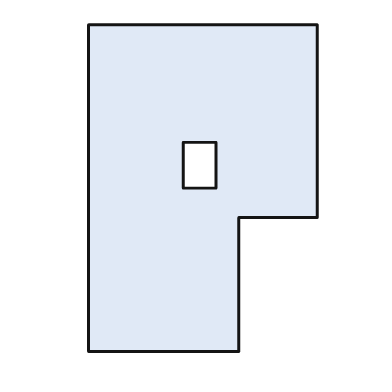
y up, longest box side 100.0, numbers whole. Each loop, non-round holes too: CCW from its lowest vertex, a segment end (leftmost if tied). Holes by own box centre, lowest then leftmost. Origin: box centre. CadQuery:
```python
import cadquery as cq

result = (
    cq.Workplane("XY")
    .moveTo(-35.0, -50.0)
    .lineTo(11.0, -50.0)
    .lineTo(11.0, -9.0)
    .lineTo(35.0, -9.0)
    .lineTo(35.0, 50.0)
    .lineTo(-35.0, 50.0)
    .close()
    .moveTo(-6.0, 0.0)
    .lineTo(4.0, 0.0)
    .lineTo(4.0, 14.0)
    .lineTo(-6.0, 14.0)
    .close()
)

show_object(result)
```